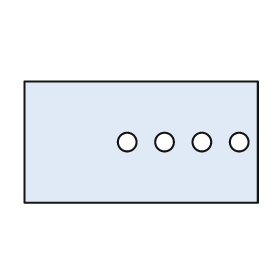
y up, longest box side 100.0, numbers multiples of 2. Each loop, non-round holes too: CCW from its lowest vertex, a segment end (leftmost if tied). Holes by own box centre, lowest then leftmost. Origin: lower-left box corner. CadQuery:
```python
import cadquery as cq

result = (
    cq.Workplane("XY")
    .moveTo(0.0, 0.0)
    .lineTo(100.0, 0.0)
    .lineTo(100.0, 52.0)
    .lineTo(0.0, 52.0)
    .close()
    .moveTo(44.0, 26.0)
    .circle(4.0)
    .moveTo(60.0, 26.0)
    .circle(4.0)
    .moveTo(76.0, 26.0)
    .circle(4.0)
    .moveTo(92.0, 26.0)
    .circle(4.0)
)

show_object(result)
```